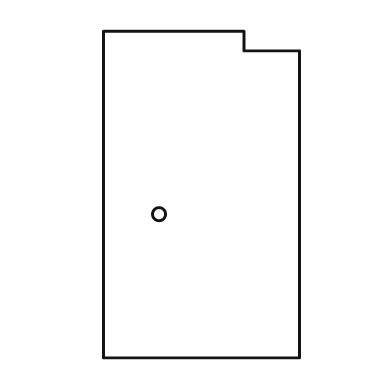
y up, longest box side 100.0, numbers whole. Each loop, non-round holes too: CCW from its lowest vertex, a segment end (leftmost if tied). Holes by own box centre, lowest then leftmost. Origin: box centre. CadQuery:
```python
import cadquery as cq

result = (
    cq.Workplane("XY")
    .moveTo(-30.0, -50.0)
    .lineTo(30.0, -50.0)
    .lineTo(30.0, 44.0)
    .lineTo(13.0, 44.0)
    .lineTo(13.0, 50.0)
    .lineTo(-30.0, 50.0)
    .close()
    .moveTo(-13.0, -6.0)
    .circle(2.0)
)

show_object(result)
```